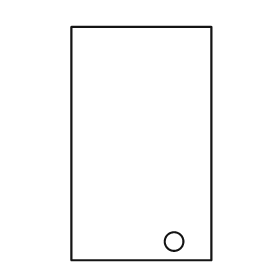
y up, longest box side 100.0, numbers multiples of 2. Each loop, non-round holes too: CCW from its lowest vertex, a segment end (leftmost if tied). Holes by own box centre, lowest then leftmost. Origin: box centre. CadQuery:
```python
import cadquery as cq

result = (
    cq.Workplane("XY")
    .moveTo(-30.0, -50.0)
    .lineTo(30.0, -50.0)
    .lineTo(30.0, 50.0)
    .lineTo(-30.0, 50.0)
    .close()
    .moveTo(14.0, -42.0)
    .circle(4.0)
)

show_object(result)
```